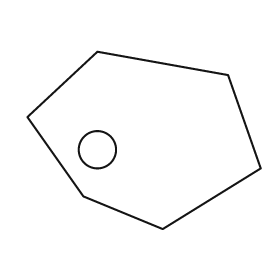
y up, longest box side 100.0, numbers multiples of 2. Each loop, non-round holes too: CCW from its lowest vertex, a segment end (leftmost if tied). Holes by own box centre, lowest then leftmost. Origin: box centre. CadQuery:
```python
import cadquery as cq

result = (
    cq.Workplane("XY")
    .moveTo(8.0, -38.0)
    .lineTo(50.0, -12.0)
    .lineTo(36.0, 28.0)
    .lineTo(-20.0, 38.0)
    .lineTo(-50.0, 10.0)
    .lineTo(-26.0, -24.0)
    .close()
    .moveTo(-20.0, -4.0)
    .circle(8.0)
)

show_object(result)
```